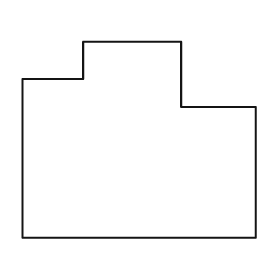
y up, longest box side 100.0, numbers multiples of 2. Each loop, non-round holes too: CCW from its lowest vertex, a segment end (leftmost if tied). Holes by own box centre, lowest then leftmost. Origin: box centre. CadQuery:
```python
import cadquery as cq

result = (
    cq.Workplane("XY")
    .moveTo(-50.0, -42.0)
    .lineTo(50.0, -42.0)
    .lineTo(50.0, 14.0)
    .lineTo(18.0, 14.0)
    .lineTo(18.0, 42.0)
    .lineTo(-24.0, 42.0)
    .lineTo(-24.0, 26.0)
    .lineTo(-50.0, 26.0)
    .close()
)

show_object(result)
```